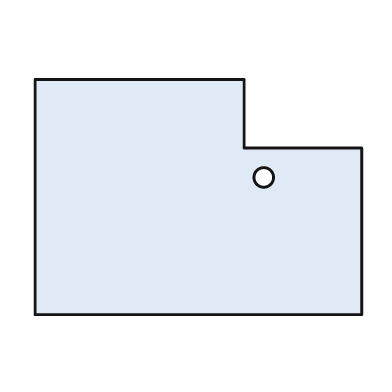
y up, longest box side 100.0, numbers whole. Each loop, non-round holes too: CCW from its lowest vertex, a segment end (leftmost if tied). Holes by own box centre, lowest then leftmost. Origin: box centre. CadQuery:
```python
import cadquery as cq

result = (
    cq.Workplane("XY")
    .moveTo(-50.0, -36.0)
    .lineTo(50.0, -36.0)
    .lineTo(50.0, 15.0)
    .lineTo(14.0, 15.0)
    .lineTo(14.0, 36.0)
    .lineTo(-50.0, 36.0)
    .close()
    .moveTo(20.0, 6.0)
    .circle(3.0)
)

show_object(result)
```